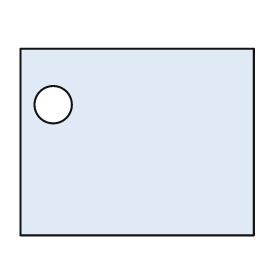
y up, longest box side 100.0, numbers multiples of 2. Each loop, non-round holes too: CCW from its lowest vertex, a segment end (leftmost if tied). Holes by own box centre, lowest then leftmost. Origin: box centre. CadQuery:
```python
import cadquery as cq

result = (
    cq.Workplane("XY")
    .moveTo(-50.0, -40.0)
    .lineTo(50.0, -40.0)
    .lineTo(50.0, 40.0)
    .lineTo(-50.0, 40.0)
    .close()
    .moveTo(-36.0, 16.0)
    .circle(8.0)
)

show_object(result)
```